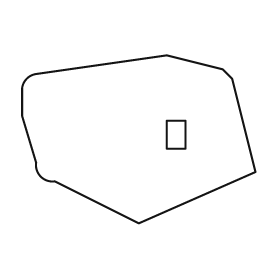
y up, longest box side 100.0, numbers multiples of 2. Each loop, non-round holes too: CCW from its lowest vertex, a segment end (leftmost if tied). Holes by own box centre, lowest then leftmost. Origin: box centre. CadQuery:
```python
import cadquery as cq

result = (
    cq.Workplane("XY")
    .moveTo(0.0, -36.0)
    .lineTo(50.0, -14.0)
    .lineTo(40.0, 26.0)
    .lineTo(36.0, 30.0)
    .lineTo(12.0, 36.0)
    .lineTo(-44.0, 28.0)
    .threePointArc((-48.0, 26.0), (-50.0, 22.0))
    .lineTo(-50.0, 10.0)
    .lineTo(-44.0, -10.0)
    .threePointArc((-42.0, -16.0), (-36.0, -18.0))
    .close()
    .moveTo(12.0, -4.0)
    .lineTo(20.0, -4.0)
    .lineTo(20.0, 8.0)
    .lineTo(12.0, 8.0)
    .close()
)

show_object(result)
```